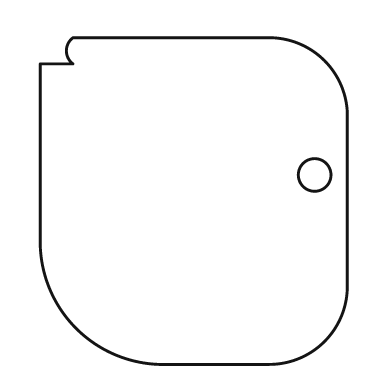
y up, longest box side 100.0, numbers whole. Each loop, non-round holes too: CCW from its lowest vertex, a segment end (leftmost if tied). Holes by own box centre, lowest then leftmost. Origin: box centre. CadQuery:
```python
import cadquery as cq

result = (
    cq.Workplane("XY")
    .moveTo(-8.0, -50.0)
    .lineTo(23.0, -50.0)
    .threePointArc((40.0, -43.0), (47.0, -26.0))
    .lineTo(47.0, 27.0)
    .threePointArc((40.0, 43.0), (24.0, 50.0))
    .lineTo(-37.0, 50.0)
    .threePointArc((-39.0, 46.0), (-37.0, 42.0))
    .lineTo(-47.0, 42.0)
    .lineTo(-47.0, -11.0)
    .threePointArc((-36.0, -39.0), (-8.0, -50.0))
    .close()
    .moveTo(37.0, 8.0)
    .circle(5.0)
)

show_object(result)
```